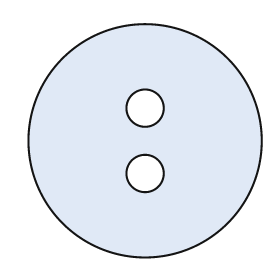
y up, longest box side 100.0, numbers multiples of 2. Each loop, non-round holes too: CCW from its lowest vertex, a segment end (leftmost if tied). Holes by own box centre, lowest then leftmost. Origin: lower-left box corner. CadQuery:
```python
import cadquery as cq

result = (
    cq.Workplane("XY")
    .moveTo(50.0, 50.0)
    .circle(50.0)
    .moveTo(50.0, 36.0)
    .circle(8.0)
    .moveTo(50.0, 64.0)
    .circle(8.0)
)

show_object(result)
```